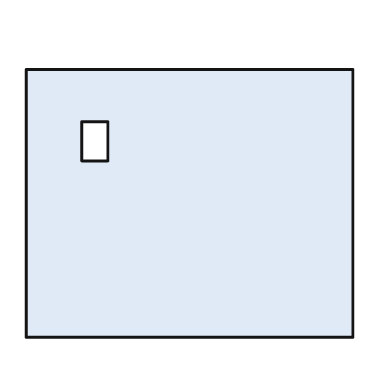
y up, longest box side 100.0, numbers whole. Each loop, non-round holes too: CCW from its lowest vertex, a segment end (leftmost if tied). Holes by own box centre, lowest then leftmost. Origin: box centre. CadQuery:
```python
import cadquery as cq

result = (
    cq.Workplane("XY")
    .moveTo(-50.0, -41.0)
    .lineTo(50.0, -41.0)
    .lineTo(50.0, 41.0)
    .lineTo(-50.0, 41.0)
    .close()
    .moveTo(-33.0, 13.0)
    .lineTo(-25.0, 13.0)
    .lineTo(-25.0, 25.0)
    .lineTo(-33.0, 25.0)
    .close()
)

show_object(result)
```